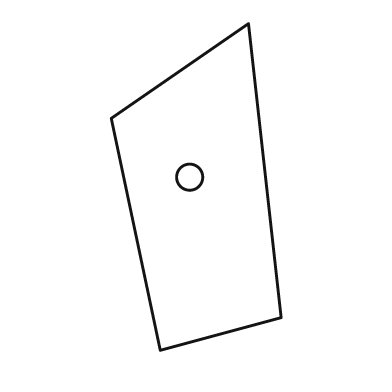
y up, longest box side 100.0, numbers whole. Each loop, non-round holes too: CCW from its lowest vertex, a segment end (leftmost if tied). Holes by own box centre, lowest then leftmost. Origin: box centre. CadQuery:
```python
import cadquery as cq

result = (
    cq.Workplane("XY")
    .moveTo(-11.0, -50.0)
    .lineTo(26.0, -40.0)
    .lineTo(16.0, 50.0)
    .lineTo(-26.0, 21.0)
    .close()
    .moveTo(-2.0, 3.0)
    .circle(4.0)
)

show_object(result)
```